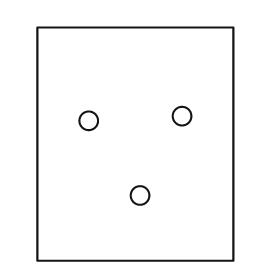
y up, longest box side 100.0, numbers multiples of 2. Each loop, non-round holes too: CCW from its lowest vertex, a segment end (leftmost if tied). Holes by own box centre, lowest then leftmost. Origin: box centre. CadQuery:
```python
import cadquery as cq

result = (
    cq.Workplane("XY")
    .moveTo(-42.0, -50.0)
    .lineTo(42.0, -50.0)
    .lineTo(42.0, 50.0)
    .lineTo(-42.0, 50.0)
    .close()
    .moveTo(2.0, -22.0)
    .circle(4.0)
    .moveTo(-20.0, 10.0)
    .circle(4.0)
    .moveTo(20.0, 12.0)
    .circle(4.0)
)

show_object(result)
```